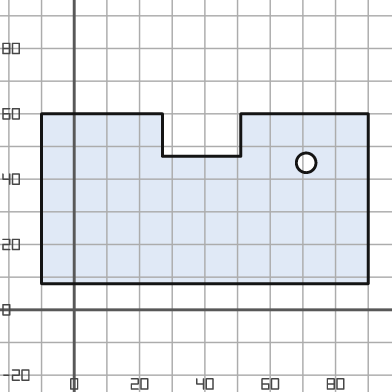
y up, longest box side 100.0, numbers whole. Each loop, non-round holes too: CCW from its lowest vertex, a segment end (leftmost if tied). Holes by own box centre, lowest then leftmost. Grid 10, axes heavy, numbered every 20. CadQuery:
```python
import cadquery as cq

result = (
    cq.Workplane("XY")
    .moveTo(-10.0, 8.0)
    .lineTo(90.0, 8.0)
    .lineTo(90.0, 60.0)
    .lineTo(51.0, 60.0)
    .lineTo(51.0, 47.0)
    .lineTo(27.0, 47.0)
    .lineTo(27.0, 60.0)
    .lineTo(-10.0, 60.0)
    .close()
    .moveTo(71.0, 45.0)
    .circle(3.0)
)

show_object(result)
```